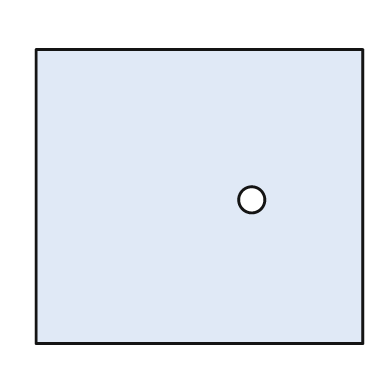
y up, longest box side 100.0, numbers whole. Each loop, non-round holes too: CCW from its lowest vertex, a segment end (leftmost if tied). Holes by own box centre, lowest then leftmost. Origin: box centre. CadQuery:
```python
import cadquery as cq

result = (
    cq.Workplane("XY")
    .moveTo(-50.0, -45.0)
    .lineTo(50.0, -45.0)
    .lineTo(50.0, 45.0)
    .lineTo(-50.0, 45.0)
    .close()
    .moveTo(16.0, -1.0)
    .circle(4.0)
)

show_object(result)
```